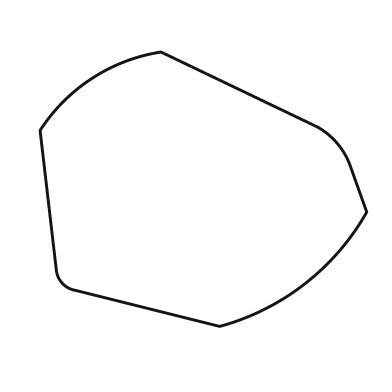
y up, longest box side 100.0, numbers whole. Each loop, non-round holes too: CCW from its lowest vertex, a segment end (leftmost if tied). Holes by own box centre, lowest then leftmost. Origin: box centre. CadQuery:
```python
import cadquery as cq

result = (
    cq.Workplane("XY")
    .moveTo(5.0, -42.0)
    .threePointArc((31.0, -29.0), (50.0, -7.0))
    .lineTo(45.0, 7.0)
    .threePointArc((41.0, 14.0), (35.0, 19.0))
    .lineTo(-13.0, 42.0)
    .threePointArc((-34.0, 34.0), (-50.0, 18.0))
    .lineTo(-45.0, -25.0)
    .threePointArc((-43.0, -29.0), (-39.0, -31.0))
    .close()
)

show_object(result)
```